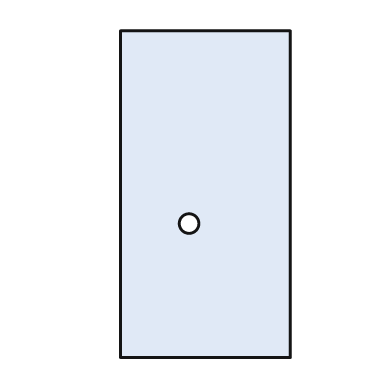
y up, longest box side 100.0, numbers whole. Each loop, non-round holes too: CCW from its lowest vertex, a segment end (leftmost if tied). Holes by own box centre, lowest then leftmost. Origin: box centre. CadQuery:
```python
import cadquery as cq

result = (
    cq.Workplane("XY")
    .moveTo(-26.0, -50.0)
    .lineTo(26.0, -50.0)
    .lineTo(26.0, 50.0)
    .lineTo(-26.0, 50.0)
    .close()
    .moveTo(-5.0, -9.0)
    .circle(3.0)
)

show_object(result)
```